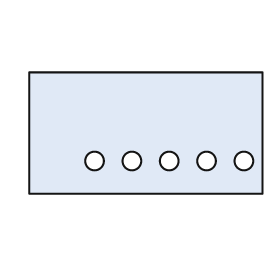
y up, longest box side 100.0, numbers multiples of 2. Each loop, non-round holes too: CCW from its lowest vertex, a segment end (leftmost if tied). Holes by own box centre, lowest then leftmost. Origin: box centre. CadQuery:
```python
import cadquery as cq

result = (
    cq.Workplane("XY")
    .moveTo(-50.0, -26.0)
    .lineTo(50.0, -26.0)
    .lineTo(50.0, 26.0)
    .lineTo(-50.0, 26.0)
    .close()
    .moveTo(-22.0, -12.0)
    .circle(4.0)
    .moveTo(-6.0, -12.0)
    .circle(4.0)
    .moveTo(10.0, -12.0)
    .circle(4.0)
    .moveTo(26.0, -12.0)
    .circle(4.0)
    .moveTo(42.0, -12.0)
    .circle(4.0)
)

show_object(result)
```